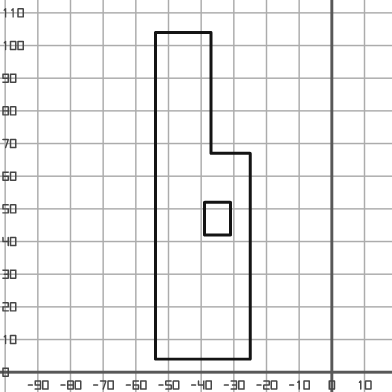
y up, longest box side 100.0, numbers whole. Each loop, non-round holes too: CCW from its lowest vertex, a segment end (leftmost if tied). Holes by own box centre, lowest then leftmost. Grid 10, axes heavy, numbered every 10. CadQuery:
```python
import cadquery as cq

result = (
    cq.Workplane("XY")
    .moveTo(-54.0, 4.0)
    .lineTo(-25.0, 4.0)
    .lineTo(-25.0, 67.0)
    .lineTo(-37.0, 67.0)
    .lineTo(-37.0, 104.0)
    .lineTo(-54.0, 104.0)
    .close()
    .moveTo(-39.0, 42.0)
    .lineTo(-31.0, 42.0)
    .lineTo(-31.0, 52.0)
    .lineTo(-39.0, 52.0)
    .close()
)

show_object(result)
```